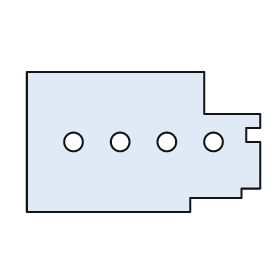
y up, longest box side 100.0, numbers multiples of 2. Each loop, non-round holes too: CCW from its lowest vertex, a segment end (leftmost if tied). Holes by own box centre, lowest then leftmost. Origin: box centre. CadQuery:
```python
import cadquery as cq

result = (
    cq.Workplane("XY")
    .moveTo(-50.0, -30.0)
    .lineTo(20.0, -30.0)
    .lineTo(20.0, -24.0)
    .lineTo(42.0, -24.0)
    .lineTo(42.0, -20.0)
    .lineTo(50.0, -20.0)
    .lineTo(50.0, 0.0)
    .lineTo(44.0, 0.0)
    .lineTo(44.0, 6.0)
    .lineTo(50.0, 6.0)
    .lineTo(50.0, 12.0)
    .lineTo(26.0, 12.0)
    .lineTo(26.0, 30.0)
    .lineTo(-50.0, 30.0)
    .close()
    .moveTo(-30.0, 0.0)
    .circle(4.0)
    .moveTo(-10.0, 0.0)
    .circle(4.0)
    .moveTo(10.0, 0.0)
    .circle(4.0)
    .moveTo(30.0, 0.0)
    .circle(4.0)
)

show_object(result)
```